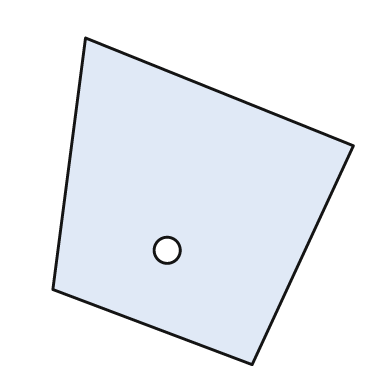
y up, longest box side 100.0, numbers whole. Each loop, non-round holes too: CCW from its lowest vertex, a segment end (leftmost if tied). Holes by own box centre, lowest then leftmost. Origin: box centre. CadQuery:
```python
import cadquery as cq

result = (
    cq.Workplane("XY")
    .moveTo(15.0, -50.0)
    .lineTo(46.0, 17.0)
    .lineTo(-36.0, 50.0)
    .lineTo(-46.0, -27.0)
    .close()
    .moveTo(-11.0, -15.0)
    .circle(4.0)
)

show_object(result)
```